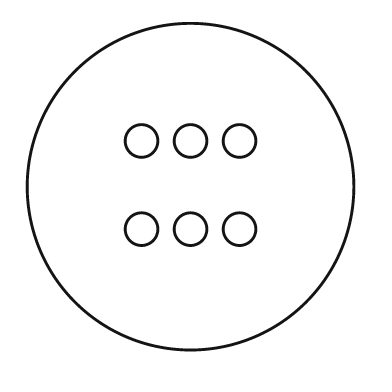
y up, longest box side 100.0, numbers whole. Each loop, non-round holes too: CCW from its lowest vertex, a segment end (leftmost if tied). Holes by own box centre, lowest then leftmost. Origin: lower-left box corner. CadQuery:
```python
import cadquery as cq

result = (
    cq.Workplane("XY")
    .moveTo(50.0, 50.0)
    .circle(50.0)
    .moveTo(35.0, 37.0)
    .circle(5.0)
    .moveTo(50.0, 37.0)
    .circle(5.0)
    .moveTo(65.0, 37.0)
    .circle(5.0)
    .moveTo(35.0, 64.0)
    .circle(5.0)
    .moveTo(50.0, 64.0)
    .circle(5.0)
    .moveTo(65.0, 64.0)
    .circle(5.0)
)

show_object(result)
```